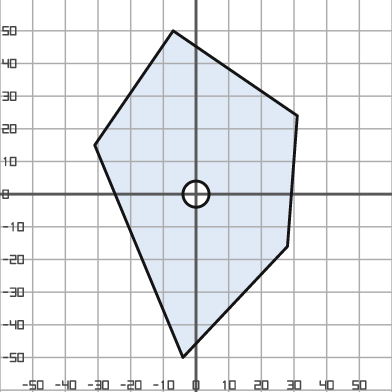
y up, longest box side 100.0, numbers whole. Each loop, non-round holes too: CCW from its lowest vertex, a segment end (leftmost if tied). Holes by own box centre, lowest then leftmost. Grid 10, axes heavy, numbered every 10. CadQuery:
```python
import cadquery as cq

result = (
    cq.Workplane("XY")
    .moveTo(-4.0, -50.0)
    .lineTo(28.0, -16.0)
    .lineTo(31.0, 24.0)
    .lineTo(-7.0, 50.0)
    .lineTo(-31.0, 15.0)
    .close()
    .moveTo(0.0, 0.0)
    .circle(4.0)
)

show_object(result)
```